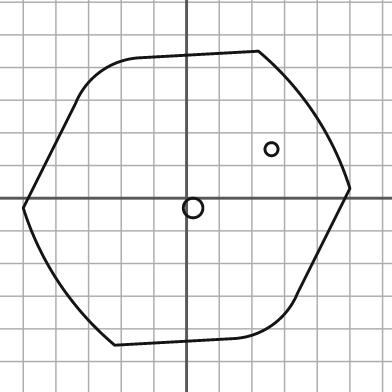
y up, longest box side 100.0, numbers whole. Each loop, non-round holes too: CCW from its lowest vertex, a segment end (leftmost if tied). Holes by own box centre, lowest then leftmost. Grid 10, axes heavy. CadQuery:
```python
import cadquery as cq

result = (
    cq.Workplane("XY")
    .moveTo(-22.0, -45.0)
    .lineTo(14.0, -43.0)
    .threePointArc((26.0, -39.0), (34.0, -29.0))
    .lineTo(50.0, 3.0)
    .threePointArc((39.0, 26.0), (22.0, 45.0))
    .lineTo(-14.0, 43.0)
    .threePointArc((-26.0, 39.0), (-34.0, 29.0))
    .lineTo(-50.0, -3.0)
    .threePointArc((-39.0, -26.0), (-22.0, -45.0))
    .close()
    .moveTo(2.0, -3.0)
    .circle(3.0)
    .moveTo(26.0, 15.0)
    .circle(2.0)
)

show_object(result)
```